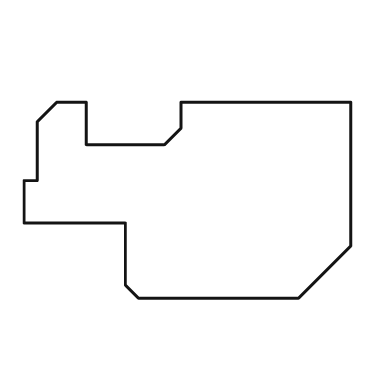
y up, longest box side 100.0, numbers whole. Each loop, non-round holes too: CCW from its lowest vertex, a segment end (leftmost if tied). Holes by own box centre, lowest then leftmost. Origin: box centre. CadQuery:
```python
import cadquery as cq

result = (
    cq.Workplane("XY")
    .moveTo(-15.0, -30.0)
    .lineTo(34.0, -30.0)
    .lineTo(50.0, -14.0)
    .lineTo(50.0, 30.0)
    .lineTo(-2.0, 30.0)
    .lineTo(-2.0, 22.0)
    .lineTo(-7.0, 17.0)
    .lineTo(-31.0, 17.0)
    .lineTo(-31.0, 30.0)
    .lineTo(-40.0, 30.0)
    .lineTo(-46.0, 24.0)
    .lineTo(-46.0, 6.0)
    .lineTo(-50.0, 6.0)
    .lineTo(-50.0, -7.0)
    .lineTo(-19.0, -7.0)
    .lineTo(-19.0, -26.0)
    .close()
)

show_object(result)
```